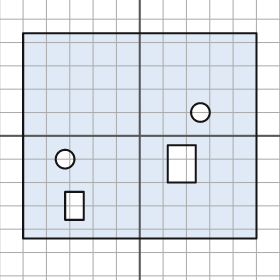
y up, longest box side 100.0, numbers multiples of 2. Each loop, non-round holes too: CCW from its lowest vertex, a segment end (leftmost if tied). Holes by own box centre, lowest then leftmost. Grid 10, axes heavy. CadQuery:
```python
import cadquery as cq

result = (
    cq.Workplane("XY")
    .moveTo(-50.0, -44.0)
    .lineTo(50.0, -44.0)
    .lineTo(50.0, 44.0)
    .lineTo(-50.0, 44.0)
    .close()
    .moveTo(-32.0, -36.0)
    .lineTo(-24.0, -36.0)
    .lineTo(-24.0, -24.0)
    .lineTo(-32.0, -24.0)
    .close()
    .moveTo(12.0, -20.0)
    .lineTo(24.0, -20.0)
    .lineTo(24.0, -4.0)
    .lineTo(12.0, -4.0)
    .close()
    .moveTo(-32.0, -10.0)
    .circle(4.0)
    .moveTo(26.0, 10.0)
    .circle(4.0)
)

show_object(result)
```